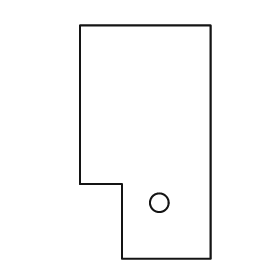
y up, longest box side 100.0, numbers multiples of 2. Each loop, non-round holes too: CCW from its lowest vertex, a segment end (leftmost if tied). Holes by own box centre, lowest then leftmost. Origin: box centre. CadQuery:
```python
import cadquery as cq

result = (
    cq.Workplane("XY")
    .moveTo(-10.0, -50.0)
    .lineTo(28.0, -50.0)
    .lineTo(28.0, 50.0)
    .lineTo(-28.0, 50.0)
    .lineTo(-28.0, -18.0)
    .lineTo(-10.0, -18.0)
    .close()
    .moveTo(6.0, -26.0)
    .circle(4.0)
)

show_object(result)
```